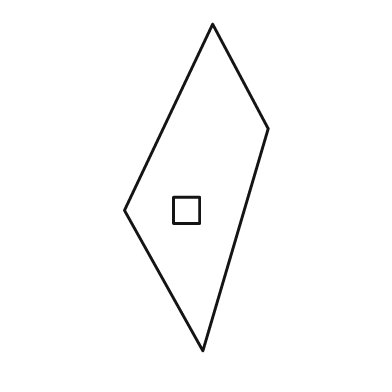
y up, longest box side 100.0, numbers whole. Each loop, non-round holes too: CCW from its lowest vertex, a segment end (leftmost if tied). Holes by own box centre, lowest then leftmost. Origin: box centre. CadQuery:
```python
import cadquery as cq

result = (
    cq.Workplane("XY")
    .moveTo(2.0, -50.0)
    .lineTo(22.0, 18.0)
    .lineTo(5.0, 50.0)
    .lineTo(-22.0, -7.0)
    .close()
    .moveTo(-7.0, -11.0)
    .lineTo(1.0, -11.0)
    .lineTo(1.0, -3.0)
    .lineTo(-7.0, -3.0)
    .close()
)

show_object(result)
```